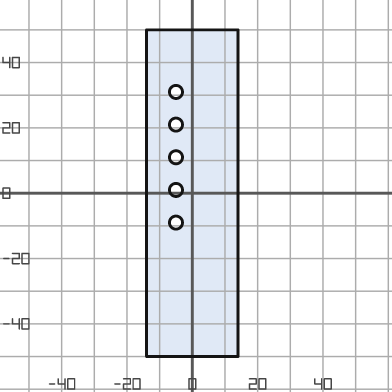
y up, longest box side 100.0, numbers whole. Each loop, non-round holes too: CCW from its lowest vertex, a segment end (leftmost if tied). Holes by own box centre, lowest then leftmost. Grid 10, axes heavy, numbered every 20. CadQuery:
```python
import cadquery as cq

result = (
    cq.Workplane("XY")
    .moveTo(-14.0, -50.0)
    .lineTo(14.0, -50.0)
    .lineTo(14.0, 50.0)
    .lineTo(-14.0, 50.0)
    .close()
    .moveTo(-5.0, -9.0)
    .circle(2.0)
    .moveTo(-5.0, 1.0)
    .circle(2.0)
    .moveTo(-5.0, 11.0)
    .circle(2.0)
    .moveTo(-5.0, 21.0)
    .circle(2.0)
    .moveTo(-5.0, 31.0)
    .circle(2.0)
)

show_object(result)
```